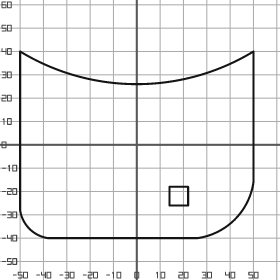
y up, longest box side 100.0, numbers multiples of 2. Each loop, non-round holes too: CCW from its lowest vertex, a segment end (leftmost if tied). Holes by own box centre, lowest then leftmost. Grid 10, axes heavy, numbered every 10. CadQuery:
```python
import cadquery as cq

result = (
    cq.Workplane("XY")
    .moveTo(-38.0, -40.0)
    .lineTo(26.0, -40.0)
    .threePointArc((42.0, -32.0), (50.0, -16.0))
    .lineTo(50.0, 40.0)
    .threePointArc((0.0, 26.0), (-50.0, 40.0))
    .lineTo(-50.0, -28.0)
    .threePointArc((-46.0, -36.0), (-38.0, -40.0))
    .close()
    .moveTo(14.0, -26.0)
    .lineTo(22.0, -26.0)
    .lineTo(22.0, -18.0)
    .lineTo(14.0, -18.0)
    .close()
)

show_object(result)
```